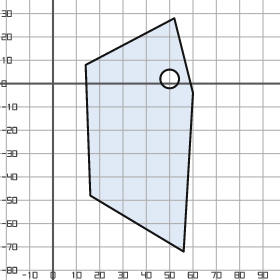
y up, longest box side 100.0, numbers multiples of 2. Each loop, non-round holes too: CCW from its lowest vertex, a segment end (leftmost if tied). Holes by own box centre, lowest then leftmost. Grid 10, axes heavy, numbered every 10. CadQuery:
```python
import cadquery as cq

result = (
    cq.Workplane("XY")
    .moveTo(56.0, -72.0)
    .lineTo(60.0, -4.0)
    .lineTo(52.0, 28.0)
    .lineTo(14.0, 8.0)
    .lineTo(16.0, -48.0)
    .close()
    .moveTo(50.0, 2.0)
    .circle(4.0)
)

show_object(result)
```